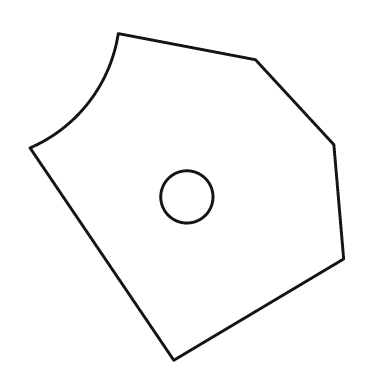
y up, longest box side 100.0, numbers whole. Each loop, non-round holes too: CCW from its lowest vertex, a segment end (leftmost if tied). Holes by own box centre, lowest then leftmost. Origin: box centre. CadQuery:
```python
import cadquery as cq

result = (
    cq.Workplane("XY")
    .moveTo(-4.0, -50.0)
    .lineTo(48.0, -19.0)
    .lineTo(45.0, 16.0)
    .lineTo(21.0, 42.0)
    .lineTo(-21.0, 50.0)
    .threePointArc((-30.0, 29.0), (-48.0, 15.0))
    .close()
    .moveTo(0.0, 0.0)
    .circle(8.0)
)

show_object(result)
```